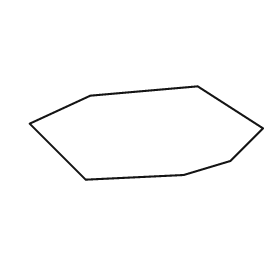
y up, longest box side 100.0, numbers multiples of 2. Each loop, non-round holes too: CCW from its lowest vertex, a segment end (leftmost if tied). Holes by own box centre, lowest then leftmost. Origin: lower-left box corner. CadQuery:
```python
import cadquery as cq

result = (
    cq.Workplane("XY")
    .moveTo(24.0, 0.0)
    .lineTo(66.0, 2.0)
    .lineTo(86.0, 8.0)
    .lineTo(100.0, 22.0)
    .lineTo(72.0, 40.0)
    .lineTo(26.0, 36.0)
    .lineTo(0.0, 24.0)
    .close()
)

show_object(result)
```